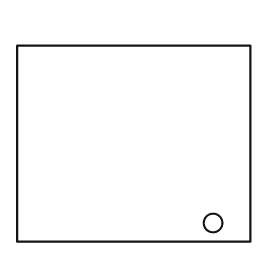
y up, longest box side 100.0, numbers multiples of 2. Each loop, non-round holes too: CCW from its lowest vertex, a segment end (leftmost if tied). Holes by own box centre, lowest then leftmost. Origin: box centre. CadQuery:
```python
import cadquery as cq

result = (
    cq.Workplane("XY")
    .moveTo(-50.0, -42.0)
    .lineTo(50.0, -42.0)
    .lineTo(50.0, 42.0)
    .lineTo(-50.0, 42.0)
    .close()
    .moveTo(34.0, -34.0)
    .circle(4.0)
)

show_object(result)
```